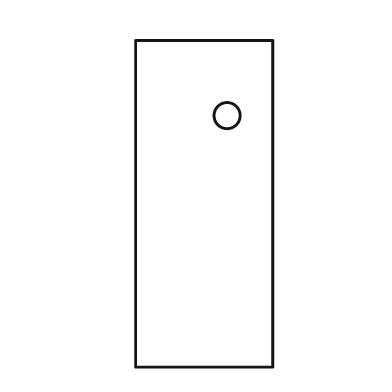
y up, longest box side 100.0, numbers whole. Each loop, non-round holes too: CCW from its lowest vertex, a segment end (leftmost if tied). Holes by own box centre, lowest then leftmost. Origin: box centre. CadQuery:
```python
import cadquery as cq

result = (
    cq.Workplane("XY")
    .moveTo(-21.0, -50.0)
    .lineTo(21.0, -50.0)
    .lineTo(21.0, 50.0)
    .lineTo(-21.0, 50.0)
    .close()
    .moveTo(7.0, 27.0)
    .circle(4.0)
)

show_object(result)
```